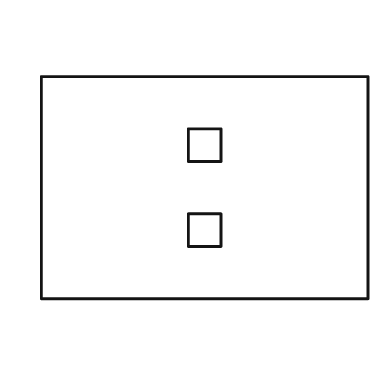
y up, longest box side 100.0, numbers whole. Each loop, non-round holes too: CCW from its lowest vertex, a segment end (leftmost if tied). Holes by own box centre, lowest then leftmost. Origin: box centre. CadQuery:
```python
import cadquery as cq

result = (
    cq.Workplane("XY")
    .moveTo(-50.0, -34.0)
    .lineTo(50.0, -34.0)
    .lineTo(50.0, 34.0)
    .lineTo(-50.0, 34.0)
    .close()
    .moveTo(-5.0, -18.0)
    .lineTo(5.0, -18.0)
    .lineTo(5.0, -8.0)
    .lineTo(-5.0, -8.0)
    .close()
    .moveTo(-5.0, 8.0)
    .lineTo(5.0, 8.0)
    .lineTo(5.0, 18.0)
    .lineTo(-5.0, 18.0)
    .close()
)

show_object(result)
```